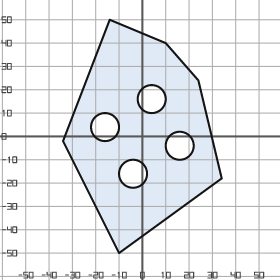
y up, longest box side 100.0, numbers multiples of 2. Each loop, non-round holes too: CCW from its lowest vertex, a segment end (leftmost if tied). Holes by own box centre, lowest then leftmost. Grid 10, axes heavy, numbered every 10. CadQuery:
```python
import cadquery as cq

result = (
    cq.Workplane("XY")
    .moveTo(-10.0, -50.0)
    .lineTo(34.0, -18.0)
    .lineTo(24.0, 24.0)
    .lineTo(10.0, 40.0)
    .lineTo(-14.0, 50.0)
    .lineTo(-34.0, -2.0)
    .close()
    .moveTo(-4.0, -16.0)
    .circle(6.0)
    .moveTo(16.0, -4.0)
    .circle(6.0)
    .moveTo(-16.0, 4.0)
    .circle(6.0)
    .moveTo(4.0, 16.0)
    .circle(6.0)
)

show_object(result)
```